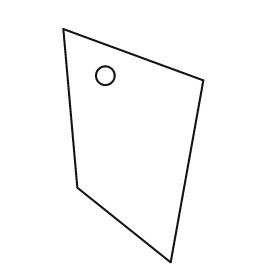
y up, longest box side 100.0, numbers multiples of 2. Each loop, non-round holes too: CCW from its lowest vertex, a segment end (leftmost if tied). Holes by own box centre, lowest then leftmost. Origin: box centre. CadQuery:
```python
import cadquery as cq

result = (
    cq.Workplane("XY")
    .moveTo(16.0, -50.0)
    .lineTo(30.0, 28.0)
    .lineTo(-30.0, 50.0)
    .lineTo(-24.0, -18.0)
    .close()
    .moveTo(-12.0, 30.0)
    .circle(4.0)
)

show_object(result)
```